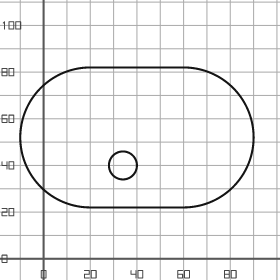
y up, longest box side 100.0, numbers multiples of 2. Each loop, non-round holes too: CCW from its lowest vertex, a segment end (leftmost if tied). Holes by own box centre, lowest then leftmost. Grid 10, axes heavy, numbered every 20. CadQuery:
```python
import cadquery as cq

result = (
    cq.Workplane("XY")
    .moveTo(20.0, 22.0)
    .lineTo(60.0, 22.0)
    .threePointArc((90.0, 52.0), (60.0, 82.0))
    .lineTo(20.0, 82.0)
    .threePointArc((-10.0, 52.0), (20.0, 22.0))
    .close()
    .moveTo(34.0, 40.0)
    .circle(6.0)
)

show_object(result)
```